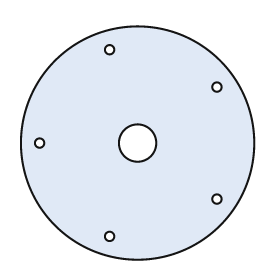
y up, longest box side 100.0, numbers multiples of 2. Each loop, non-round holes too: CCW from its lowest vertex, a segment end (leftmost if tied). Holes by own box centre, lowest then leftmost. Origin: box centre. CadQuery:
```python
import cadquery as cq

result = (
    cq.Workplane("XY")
    .moveTo(0.0, 0.0)
    .circle(50.0)
    .moveTo(-12.0, -40.0)
    .circle(2.0)
    .moveTo(34.0, -24.0)
    .circle(2.0)
    .moveTo(-42.0, 0.0)
    .circle(2.0)
    .moveTo(0.0, 0.0)
    .circle(8.0)
    .moveTo(34.0, 24.0)
    .circle(2.0)
    .moveTo(-12.0, 40.0)
    .circle(2.0)
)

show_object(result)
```